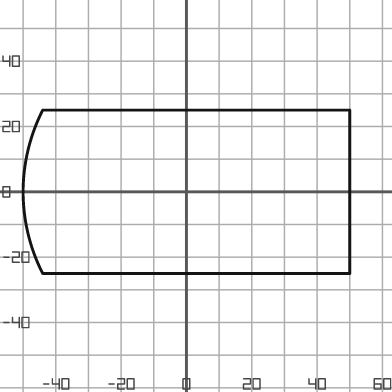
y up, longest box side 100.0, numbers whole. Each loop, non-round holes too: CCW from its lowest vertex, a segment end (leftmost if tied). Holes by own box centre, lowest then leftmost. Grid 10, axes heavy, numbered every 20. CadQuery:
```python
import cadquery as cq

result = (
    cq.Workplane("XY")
    .moveTo(-44.0, -25.0)
    .lineTo(50.0, -25.0)
    .lineTo(50.0, 25.0)
    .lineTo(-44.0, 25.0)
    .threePointArc((-50.0, 0.0), (-44.0, -25.0))
    .close()
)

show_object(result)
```